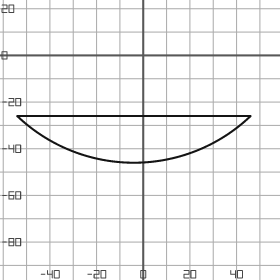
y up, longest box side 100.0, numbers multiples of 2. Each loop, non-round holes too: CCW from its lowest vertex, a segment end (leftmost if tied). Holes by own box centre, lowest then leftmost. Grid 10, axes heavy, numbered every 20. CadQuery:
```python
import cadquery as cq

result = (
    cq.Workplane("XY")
    .moveTo(-54.0, -26.0)
    .threePointArc((-4.0, -46.0), (46.0, -26.0))
    .close()
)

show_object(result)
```